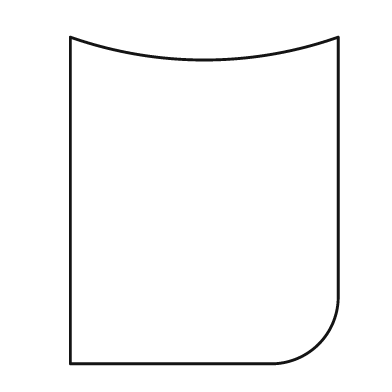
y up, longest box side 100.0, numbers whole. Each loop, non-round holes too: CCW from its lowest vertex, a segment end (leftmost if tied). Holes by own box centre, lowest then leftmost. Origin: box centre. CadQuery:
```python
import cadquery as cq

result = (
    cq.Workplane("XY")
    .moveTo(-41.0, -50.0)
    .lineTo(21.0, -50.0)
    .threePointArc((35.0, -44.0), (41.0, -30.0))
    .lineTo(41.0, 50.0)
    .threePointArc((0.0, 43.0), (-41.0, 50.0))
    .close()
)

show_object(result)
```